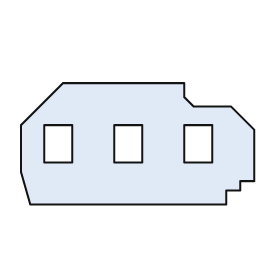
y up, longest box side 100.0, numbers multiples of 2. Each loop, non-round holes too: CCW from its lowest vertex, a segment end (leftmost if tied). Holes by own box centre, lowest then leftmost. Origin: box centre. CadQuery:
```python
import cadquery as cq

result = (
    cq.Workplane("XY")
    .moveTo(-46.0, -26.0)
    .lineTo(38.0, -26.0)
    .lineTo(38.0, -20.0)
    .lineTo(44.0, -20.0)
    .lineTo(44.0, -16.0)
    .lineTo(50.0, -16.0)
    .lineTo(50.0, 6.0)
    .lineTo(40.0, 16.0)
    .lineTo(24.0, 16.0)
    .lineTo(20.0, 20.0)
    .lineTo(20.0, 26.0)
    .lineTo(-32.0, 26.0)
    .lineTo(-50.0, 8.0)
    .lineTo(-50.0, -12.0)
    .close()
    .moveTo(-40.0, -8.0)
    .lineTo(-28.0, -8.0)
    .lineTo(-28.0, 8.0)
    .lineTo(-40.0, 8.0)
    .close()
    .moveTo(-10.0, -8.0)
    .lineTo(2.0, -8.0)
    .lineTo(2.0, 8.0)
    .lineTo(-10.0, 8.0)
    .close()
    .moveTo(20.0, -8.0)
    .lineTo(32.0, -8.0)
    .lineTo(32.0, 8.0)
    .lineTo(20.0, 8.0)
    .close()
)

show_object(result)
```